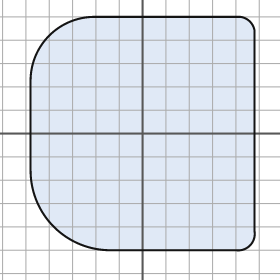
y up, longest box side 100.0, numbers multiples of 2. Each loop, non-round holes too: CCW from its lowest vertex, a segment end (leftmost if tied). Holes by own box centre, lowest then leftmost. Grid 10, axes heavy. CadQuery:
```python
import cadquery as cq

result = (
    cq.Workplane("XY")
    .moveTo(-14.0, -50.0)
    .lineTo(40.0, -50.0)
    .threePointArc((46.0, -48.0), (48.0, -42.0))
    .lineTo(48.0, 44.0)
    .threePointArc((46.0, 48.0), (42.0, 50.0))
    .lineTo(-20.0, 50.0)
    .threePointArc((-40.0, 42.0), (-48.0, 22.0))
    .lineTo(-48.0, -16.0)
    .threePointArc((-38.0, -40.0), (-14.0, -50.0))
    .close()
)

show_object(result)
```